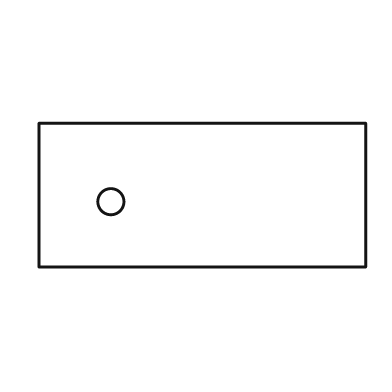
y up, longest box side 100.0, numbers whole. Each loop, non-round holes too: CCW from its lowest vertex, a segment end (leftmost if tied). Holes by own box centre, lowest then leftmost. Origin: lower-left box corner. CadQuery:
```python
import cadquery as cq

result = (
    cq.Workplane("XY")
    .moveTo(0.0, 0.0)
    .lineTo(100.0, 0.0)
    .lineTo(100.0, 44.0)
    .lineTo(0.0, 44.0)
    .close()
    .moveTo(22.0, 20.0)
    .circle(4.0)
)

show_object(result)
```